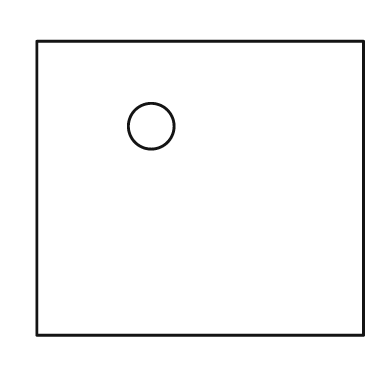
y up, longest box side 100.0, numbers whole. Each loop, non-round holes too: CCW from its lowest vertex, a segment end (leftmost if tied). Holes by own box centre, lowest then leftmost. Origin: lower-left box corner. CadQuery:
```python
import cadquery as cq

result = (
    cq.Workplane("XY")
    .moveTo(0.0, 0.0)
    .lineTo(100.0, 0.0)
    .lineTo(100.0, 90.0)
    .lineTo(0.0, 90.0)
    .close()
    .moveTo(35.0, 64.0)
    .circle(7.0)
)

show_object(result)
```